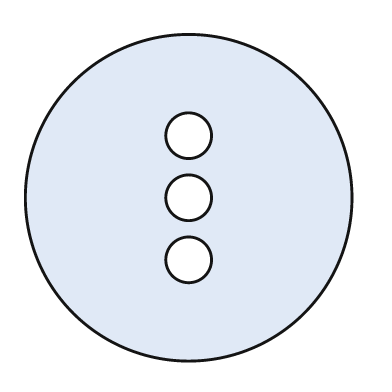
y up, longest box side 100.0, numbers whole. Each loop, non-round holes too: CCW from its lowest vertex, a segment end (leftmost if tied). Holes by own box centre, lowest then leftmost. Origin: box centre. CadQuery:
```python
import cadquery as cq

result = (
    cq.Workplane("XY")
    .moveTo(0.0, 0.0)
    .circle(50.0)
    .moveTo(0.0, -19.0)
    .circle(7.0)
    .moveTo(0.0, 0.0)
    .circle(7.0)
    .moveTo(0.0, 19.0)
    .circle(7.0)
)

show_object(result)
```